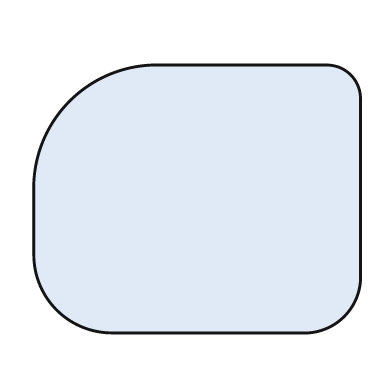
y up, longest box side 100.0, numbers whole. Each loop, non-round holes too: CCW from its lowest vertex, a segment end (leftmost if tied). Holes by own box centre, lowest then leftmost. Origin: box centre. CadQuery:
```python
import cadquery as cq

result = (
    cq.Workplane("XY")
    .moveTo(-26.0, -41.0)
    .lineTo(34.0, -41.0)
    .threePointArc((45.0, -36.0), (50.0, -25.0))
    .lineTo(50.0, 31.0)
    .threePointArc((47.0, 38.0), (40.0, 41.0))
    .lineTo(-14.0, 41.0)
    .threePointArc((-39.0, 30.0), (-50.0, 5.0))
    .lineTo(-50.0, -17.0)
    .threePointArc((-43.0, -34.0), (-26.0, -41.0))
    .close()
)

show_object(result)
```